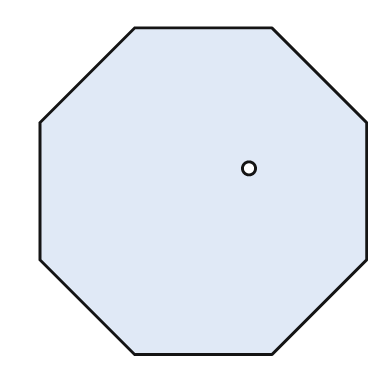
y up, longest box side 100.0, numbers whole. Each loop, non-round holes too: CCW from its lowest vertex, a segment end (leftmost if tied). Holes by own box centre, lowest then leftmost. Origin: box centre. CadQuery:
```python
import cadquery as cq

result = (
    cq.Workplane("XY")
    .moveTo(-21.0, -50.0)
    .lineTo(21.0, -50.0)
    .lineTo(50.0, -21.0)
    .lineTo(50.0, 21.0)
    .lineTo(21.0, 50.0)
    .lineTo(-21.0, 50.0)
    .lineTo(-50.0, 21.0)
    .lineTo(-50.0, -21.0)
    .close()
    .moveTo(14.0, 7.0)
    .circle(2.0)
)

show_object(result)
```